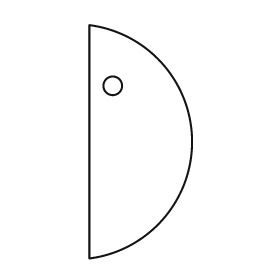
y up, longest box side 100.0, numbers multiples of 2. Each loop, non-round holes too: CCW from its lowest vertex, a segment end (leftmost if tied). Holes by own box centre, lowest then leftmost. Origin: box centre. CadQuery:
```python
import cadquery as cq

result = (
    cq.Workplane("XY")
    .moveTo(-22.0, -50.0)
    .threePointArc((22.0, 0.0), (-22.0, 50.0))
    .close()
    .moveTo(-12.0, 24.0)
    .circle(4.0)
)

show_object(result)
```